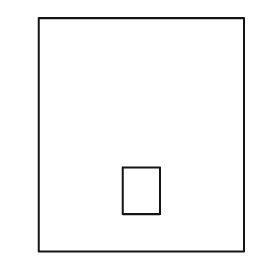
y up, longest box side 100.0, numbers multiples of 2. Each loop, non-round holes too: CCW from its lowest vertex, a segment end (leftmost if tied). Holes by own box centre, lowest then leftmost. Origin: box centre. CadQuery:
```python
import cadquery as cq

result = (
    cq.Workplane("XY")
    .moveTo(-44.0, -50.0)
    .lineTo(44.0, -50.0)
    .lineTo(44.0, 50.0)
    .lineTo(-44.0, 50.0)
    .close()
    .moveTo(-8.0, -34.0)
    .lineTo(8.0, -34.0)
    .lineTo(8.0, -14.0)
    .lineTo(-8.0, -14.0)
    .close()
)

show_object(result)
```